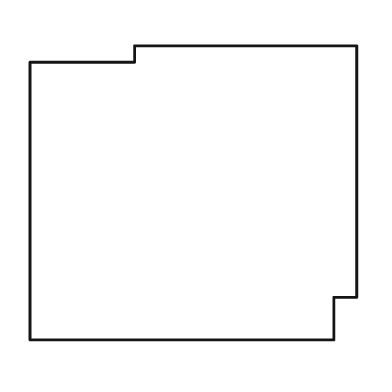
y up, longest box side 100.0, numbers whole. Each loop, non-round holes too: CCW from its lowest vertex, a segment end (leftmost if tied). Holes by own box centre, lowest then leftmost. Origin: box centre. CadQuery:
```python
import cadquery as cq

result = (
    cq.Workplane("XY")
    .moveTo(-50.0, -45.0)
    .lineTo(43.0, -45.0)
    .lineTo(43.0, -32.0)
    .lineTo(50.0, -32.0)
    .lineTo(50.0, 45.0)
    .lineTo(-18.0, 45.0)
    .lineTo(-18.0, 40.0)
    .lineTo(-50.0, 40.0)
    .close()
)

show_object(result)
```